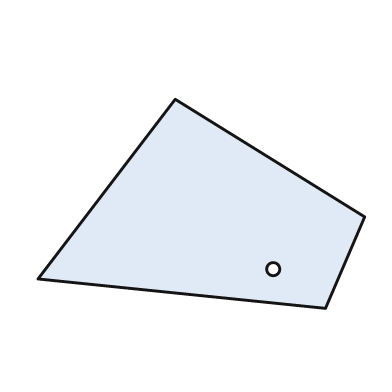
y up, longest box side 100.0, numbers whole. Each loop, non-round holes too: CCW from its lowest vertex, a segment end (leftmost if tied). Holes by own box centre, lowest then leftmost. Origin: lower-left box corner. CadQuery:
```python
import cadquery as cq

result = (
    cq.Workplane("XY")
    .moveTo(88.0, 0.0)
    .lineTo(100.0, 28.0)
    .lineTo(42.0, 64.0)
    .lineTo(0.0, 9.0)
    .close()
    .moveTo(72.0, 12.0)
    .circle(2.0)
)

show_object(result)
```